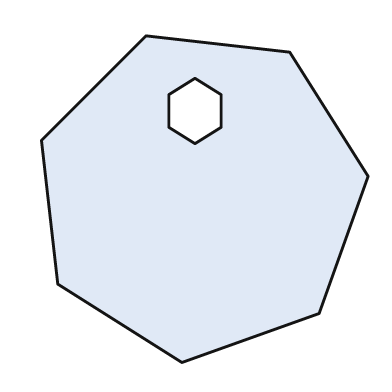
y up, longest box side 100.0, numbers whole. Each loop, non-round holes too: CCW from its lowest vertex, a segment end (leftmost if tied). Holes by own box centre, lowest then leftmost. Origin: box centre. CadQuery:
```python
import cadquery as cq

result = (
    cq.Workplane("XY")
    .moveTo(-7.0, -50.0)
    .lineTo(35.0, -35.0)
    .lineTo(50.0, 7.0)
    .lineTo(26.0, 45.0)
    .lineTo(-18.0, 50.0)
    .lineTo(-50.0, 18.0)
    .lineTo(-45.0, -26.0)
    .close()
    .moveTo(-3.0, 17.0)
    .lineTo(5.0, 22.0)
    .lineTo(5.0, 32.0)
    .lineTo(-3.0, 37.0)
    .lineTo(-11.0, 32.0)
    .lineTo(-11.0, 22.0)
    .close()
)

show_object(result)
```